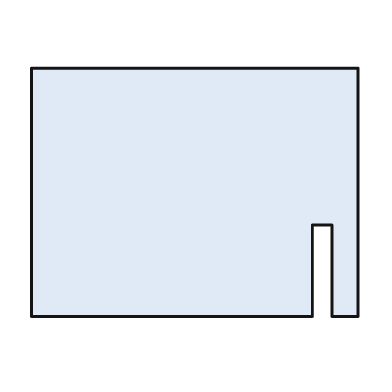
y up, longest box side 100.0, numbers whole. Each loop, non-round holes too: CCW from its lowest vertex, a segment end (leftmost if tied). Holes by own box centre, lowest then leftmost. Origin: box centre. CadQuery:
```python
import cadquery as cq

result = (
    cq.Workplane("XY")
    .moveTo(-50.0, -38.0)
    .lineTo(36.0, -38.0)
    .lineTo(36.0, -10.0)
    .lineTo(42.0, -10.0)
    .lineTo(42.0, -38.0)
    .lineTo(50.0, -38.0)
    .lineTo(50.0, 38.0)
    .lineTo(-50.0, 38.0)
    .close()
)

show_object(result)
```